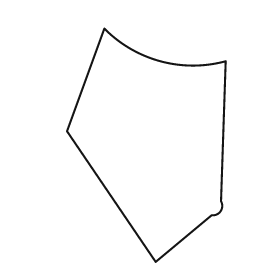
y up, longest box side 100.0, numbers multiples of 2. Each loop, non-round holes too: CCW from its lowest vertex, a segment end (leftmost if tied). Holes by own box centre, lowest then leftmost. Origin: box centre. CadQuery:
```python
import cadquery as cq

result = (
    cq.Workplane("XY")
    .moveTo(4.0, -50.0)
    .lineTo(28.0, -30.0)
    .threePointArc((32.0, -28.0), (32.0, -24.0))
    .lineTo(34.0, 36.0)
    .threePointArc((6.0, 36.0), (-18.0, 50.0))
    .lineTo(-34.0, 6.0)
    .close()
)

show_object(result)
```